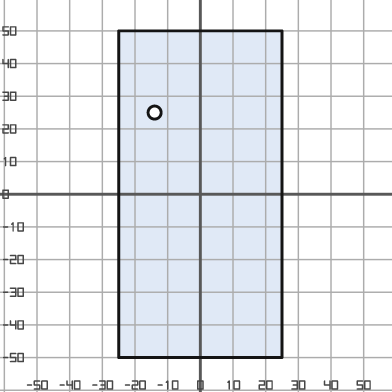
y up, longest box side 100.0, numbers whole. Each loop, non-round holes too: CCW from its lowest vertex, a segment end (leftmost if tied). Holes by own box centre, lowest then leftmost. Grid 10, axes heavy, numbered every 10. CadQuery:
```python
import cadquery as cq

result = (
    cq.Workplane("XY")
    .moveTo(-25.0, -50.0)
    .lineTo(25.0, -50.0)
    .lineTo(25.0, 50.0)
    .lineTo(-25.0, 50.0)
    .close()
    .moveTo(-14.0, 25.0)
    .circle(2.0)
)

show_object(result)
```